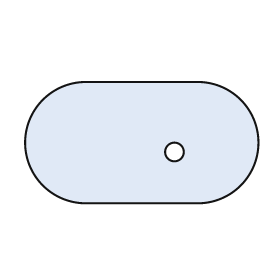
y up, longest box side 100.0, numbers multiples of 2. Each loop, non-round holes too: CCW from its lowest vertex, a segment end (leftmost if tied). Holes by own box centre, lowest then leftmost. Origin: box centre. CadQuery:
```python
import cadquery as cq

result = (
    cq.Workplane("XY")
    .moveTo(-24.0, -26.0)
    .lineTo(24.0, -26.0)
    .threePointArc((50.0, 0.0), (24.0, 26.0))
    .lineTo(-24.0, 26.0)
    .threePointArc((-50.0, 0.0), (-24.0, -26.0))
    .close()
    .moveTo(14.0, -4.0)
    .circle(4.0)
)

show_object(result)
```